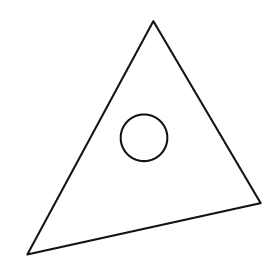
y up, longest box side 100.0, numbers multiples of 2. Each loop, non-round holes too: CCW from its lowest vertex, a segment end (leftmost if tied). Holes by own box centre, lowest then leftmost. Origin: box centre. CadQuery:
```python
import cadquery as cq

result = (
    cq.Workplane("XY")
    .moveTo(-50.0, -50.0)
    .lineTo(50.0, -28.0)
    .lineTo(4.0, 50.0)
    .close()
    .moveTo(0.0, 0.0)
    .circle(10.0)
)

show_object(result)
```